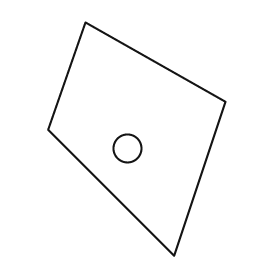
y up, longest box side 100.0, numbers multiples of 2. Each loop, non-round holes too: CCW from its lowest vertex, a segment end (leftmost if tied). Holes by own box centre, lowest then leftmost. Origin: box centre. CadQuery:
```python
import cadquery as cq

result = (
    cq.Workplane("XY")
    .moveTo(16.0, -50.0)
    .lineTo(38.0, 16.0)
    .lineTo(-22.0, 50.0)
    .lineTo(-38.0, 4.0)
    .close()
    .moveTo(-4.0, -4.0)
    .circle(6.0)
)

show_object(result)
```